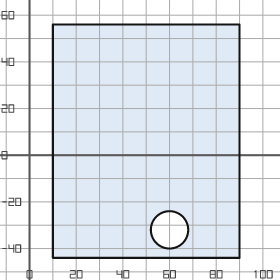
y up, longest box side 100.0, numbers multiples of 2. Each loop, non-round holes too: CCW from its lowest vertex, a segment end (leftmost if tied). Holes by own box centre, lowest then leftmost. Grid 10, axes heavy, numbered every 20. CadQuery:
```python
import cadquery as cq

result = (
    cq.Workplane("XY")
    .moveTo(10.0, -44.0)
    .lineTo(90.0, -44.0)
    .lineTo(90.0, 56.0)
    .lineTo(10.0, 56.0)
    .close()
    .moveTo(60.0, -32.0)
    .circle(8.0)
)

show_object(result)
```